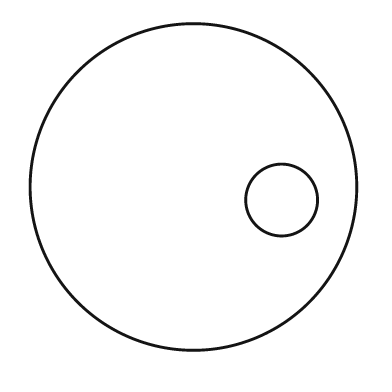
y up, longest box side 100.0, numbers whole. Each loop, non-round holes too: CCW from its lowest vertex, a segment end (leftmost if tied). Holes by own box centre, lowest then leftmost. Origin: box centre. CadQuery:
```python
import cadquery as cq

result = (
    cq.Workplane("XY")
    .moveTo(0.0, 0.0)
    .circle(50.0)
    .moveTo(27.0, -4.0)
    .circle(11.0)
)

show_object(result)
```